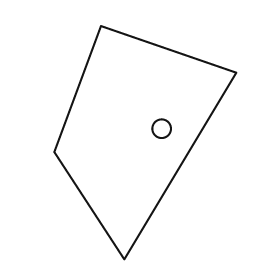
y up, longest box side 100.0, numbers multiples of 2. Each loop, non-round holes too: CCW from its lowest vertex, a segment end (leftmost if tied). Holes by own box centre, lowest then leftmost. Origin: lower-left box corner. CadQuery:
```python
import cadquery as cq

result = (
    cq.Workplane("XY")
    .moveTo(30.0, 0.0)
    .lineTo(78.0, 80.0)
    .lineTo(20.0, 100.0)
    .lineTo(0.0, 46.0)
    .close()
    .moveTo(46.0, 56.0)
    .circle(4.0)
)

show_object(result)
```